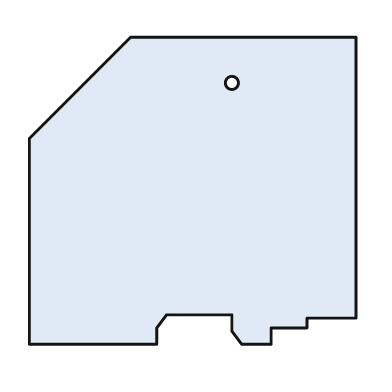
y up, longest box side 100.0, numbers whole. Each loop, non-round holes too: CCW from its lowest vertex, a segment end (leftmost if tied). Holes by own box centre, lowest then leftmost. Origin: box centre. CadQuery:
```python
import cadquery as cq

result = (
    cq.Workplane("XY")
    .moveTo(-50.0, -47.0)
    .lineTo(-11.0, -47.0)
    .lineTo(-11.0, -42.0)
    .lineTo(-8.0, -38.0)
    .lineTo(12.0, -38.0)
    .lineTo(12.0, -43.0)
    .lineTo(15.0, -47.0)
    .lineTo(24.0, -47.0)
    .lineTo(24.0, -42.0)
    .lineTo(35.0, -42.0)
    .lineTo(35.0, -39.0)
    .lineTo(50.0, -39.0)
    .lineTo(50.0, 47.0)
    .lineTo(-19.0, 47.0)
    .lineTo(-50.0, 16.0)
    .close()
    .moveTo(12.0, 33.0)
    .circle(2.0)
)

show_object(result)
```